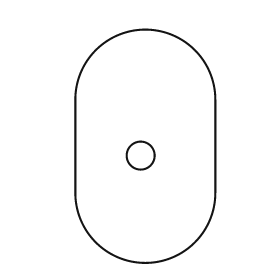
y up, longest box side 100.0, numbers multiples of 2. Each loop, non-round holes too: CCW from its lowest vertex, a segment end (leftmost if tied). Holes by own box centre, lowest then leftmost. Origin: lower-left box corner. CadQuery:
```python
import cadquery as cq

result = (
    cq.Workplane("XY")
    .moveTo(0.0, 30.0)
    .threePointArc((30.0, 0.0), (60.0, 30.0))
    .lineTo(60.0, 70.0)
    .threePointArc((30.0, 100.0), (0.0, 70.0))
    .close()
    .moveTo(28.0, 46.0)
    .circle(6.0)
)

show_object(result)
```